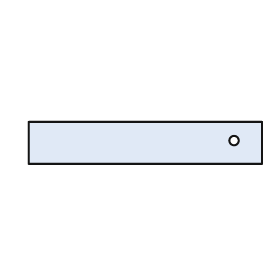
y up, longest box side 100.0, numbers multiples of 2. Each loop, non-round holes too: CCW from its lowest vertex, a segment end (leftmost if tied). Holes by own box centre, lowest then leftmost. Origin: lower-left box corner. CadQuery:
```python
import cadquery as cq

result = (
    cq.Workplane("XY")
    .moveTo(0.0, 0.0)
    .lineTo(100.0, 0.0)
    .lineTo(100.0, 18.0)
    .lineTo(0.0, 18.0)
    .close()
    .moveTo(88.0, 10.0)
    .circle(2.0)
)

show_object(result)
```